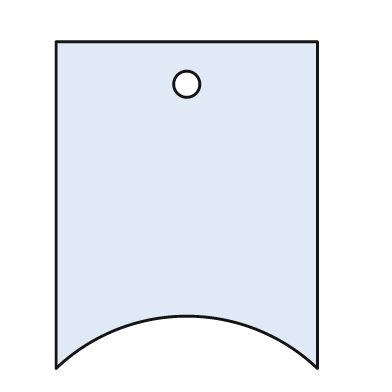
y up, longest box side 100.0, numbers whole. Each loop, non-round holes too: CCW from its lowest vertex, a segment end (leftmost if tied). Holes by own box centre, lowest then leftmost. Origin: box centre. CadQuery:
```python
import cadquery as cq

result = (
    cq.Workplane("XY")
    .moveTo(-40.0, -50.0)
    .threePointArc((0.0, -34.0), (40.0, -50.0))
    .lineTo(40.0, 50.0)
    .lineTo(-40.0, 50.0)
    .close()
    .moveTo(0.0, 37.0)
    .circle(4.0)
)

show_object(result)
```